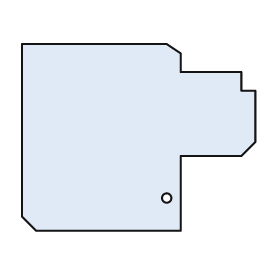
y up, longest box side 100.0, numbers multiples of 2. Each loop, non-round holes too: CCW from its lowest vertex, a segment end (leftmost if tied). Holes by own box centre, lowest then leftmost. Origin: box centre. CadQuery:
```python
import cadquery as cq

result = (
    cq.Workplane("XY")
    .moveTo(-44.0, -40.0)
    .lineTo(18.0, -40.0)
    .lineTo(18.0, -8.0)
    .lineTo(44.0, -8.0)
    .lineTo(50.0, -2.0)
    .lineTo(50.0, 20.0)
    .lineTo(44.0, 20.0)
    .lineTo(44.0, 28.0)
    .lineTo(18.0, 28.0)
    .lineTo(18.0, 36.0)
    .lineTo(12.0, 40.0)
    .lineTo(-50.0, 40.0)
    .lineTo(-50.0, -34.0)
    .close()
    .moveTo(12.0, -26.0)
    .circle(2.0)
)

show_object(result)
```